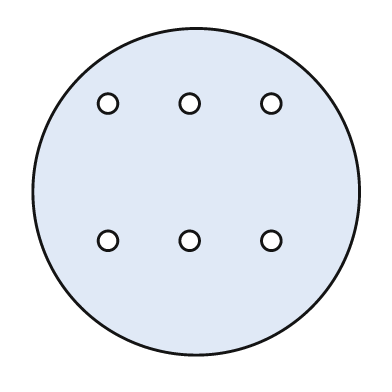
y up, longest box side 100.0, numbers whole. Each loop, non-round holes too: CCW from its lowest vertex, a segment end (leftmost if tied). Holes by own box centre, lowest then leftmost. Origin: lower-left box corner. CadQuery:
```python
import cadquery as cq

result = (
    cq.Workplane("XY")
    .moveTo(50.0, 50.0)
    .circle(50.0)
    .moveTo(23.0, 35.0)
    .circle(3.0)
    .moveTo(48.0, 35.0)
    .circle(3.0)
    .moveTo(73.0, 35.0)
    .circle(3.0)
    .moveTo(23.0, 77.0)
    .circle(3.0)
    .moveTo(48.0, 77.0)
    .circle(3.0)
    .moveTo(73.0, 77.0)
    .circle(3.0)
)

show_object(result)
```